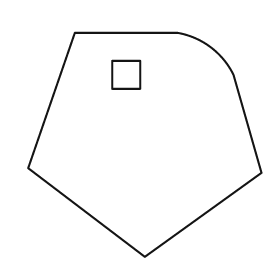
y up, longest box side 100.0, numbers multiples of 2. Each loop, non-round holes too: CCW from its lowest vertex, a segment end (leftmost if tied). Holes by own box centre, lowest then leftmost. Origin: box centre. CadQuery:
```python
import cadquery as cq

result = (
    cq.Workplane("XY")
    .moveTo(0.0, -48.0)
    .lineTo(50.0, -12.0)
    .lineTo(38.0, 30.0)
    .threePointArc((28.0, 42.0), (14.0, 48.0))
    .lineTo(-30.0, 48.0)
    .lineTo(-50.0, -10.0)
    .close()
    .moveTo(-14.0, 24.0)
    .lineTo(-2.0, 24.0)
    .lineTo(-2.0, 36.0)
    .lineTo(-14.0, 36.0)
    .close()
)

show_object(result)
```